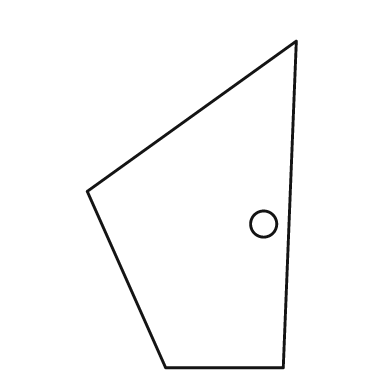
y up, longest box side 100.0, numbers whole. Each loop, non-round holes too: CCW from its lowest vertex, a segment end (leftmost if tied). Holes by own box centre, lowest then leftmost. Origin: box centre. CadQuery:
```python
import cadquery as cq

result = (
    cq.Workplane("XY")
    .moveTo(-8.0, -50.0)
    .lineTo(28.0, -50.0)
    .lineTo(32.0, 50.0)
    .lineTo(-32.0, 4.0)
    .close()
    .moveTo(22.0, -6.0)
    .circle(4.0)
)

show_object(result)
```